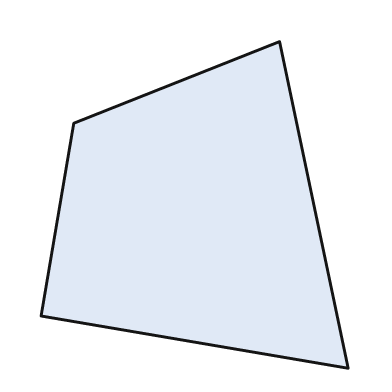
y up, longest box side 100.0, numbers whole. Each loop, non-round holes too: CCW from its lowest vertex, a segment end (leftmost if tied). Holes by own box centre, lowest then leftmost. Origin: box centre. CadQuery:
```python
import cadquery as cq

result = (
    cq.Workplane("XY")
    .moveTo(47.0, -50.0)
    .lineTo(26.0, 50.0)
    .lineTo(-37.0, 25.0)
    .lineTo(-47.0, -34.0)
    .close()
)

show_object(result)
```